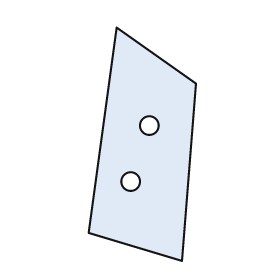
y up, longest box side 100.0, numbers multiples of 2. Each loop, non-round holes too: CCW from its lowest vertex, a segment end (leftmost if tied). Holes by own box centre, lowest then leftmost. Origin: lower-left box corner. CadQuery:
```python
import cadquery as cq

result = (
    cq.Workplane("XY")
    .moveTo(40.0, 0.0)
    .lineTo(46.0, 76.0)
    .lineTo(12.0, 100.0)
    .lineTo(0.0, 12.0)
    .close()
    .moveTo(18.0, 34.0)
    .circle(4.0)
    .moveTo(26.0, 58.0)
    .circle(4.0)
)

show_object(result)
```